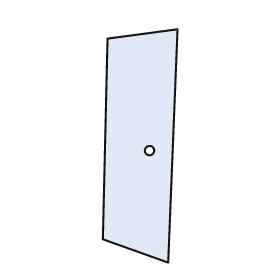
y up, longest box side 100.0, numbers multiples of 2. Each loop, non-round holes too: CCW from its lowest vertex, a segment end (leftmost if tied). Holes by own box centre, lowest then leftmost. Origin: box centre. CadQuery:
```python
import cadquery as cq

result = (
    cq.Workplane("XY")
    .moveTo(12.0, -50.0)
    .lineTo(16.0, 50.0)
    .lineTo(-14.0, 46.0)
    .lineTo(-16.0, -40.0)
    .close()
    .moveTo(4.0, -2.0)
    .circle(2.0)
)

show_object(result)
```